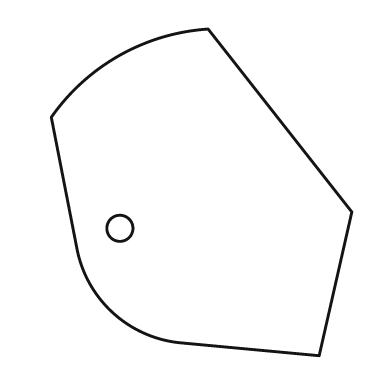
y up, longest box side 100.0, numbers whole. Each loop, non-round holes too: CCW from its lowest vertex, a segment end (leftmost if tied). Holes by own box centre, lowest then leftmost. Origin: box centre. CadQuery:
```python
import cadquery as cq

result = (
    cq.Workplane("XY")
    .moveTo(36.0, -50.0)
    .lineTo(46.0, -6.0)
    .lineTo(2.0, 50.0)
    .threePointArc((-25.0, 42.0), (-46.0, 23.0))
    .lineTo(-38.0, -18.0)
    .threePointArc((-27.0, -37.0), (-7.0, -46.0))
    .close()
    .moveTo(-25.0, -11.0)
    .circle(4.0)
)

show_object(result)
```